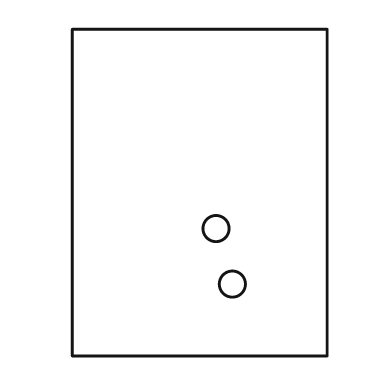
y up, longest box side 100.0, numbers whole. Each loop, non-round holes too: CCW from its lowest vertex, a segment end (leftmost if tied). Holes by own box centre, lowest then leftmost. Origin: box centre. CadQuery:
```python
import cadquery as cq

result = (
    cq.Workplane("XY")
    .moveTo(-39.0, -50.0)
    .lineTo(39.0, -50.0)
    .lineTo(39.0, 50.0)
    .lineTo(-39.0, 50.0)
    .close()
    .moveTo(10.0, -28.0)
    .circle(4.0)
    .moveTo(5.0, -11.0)
    .circle(4.0)
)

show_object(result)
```